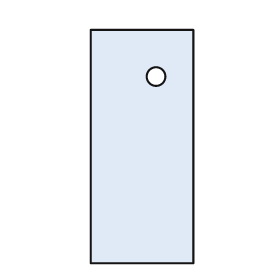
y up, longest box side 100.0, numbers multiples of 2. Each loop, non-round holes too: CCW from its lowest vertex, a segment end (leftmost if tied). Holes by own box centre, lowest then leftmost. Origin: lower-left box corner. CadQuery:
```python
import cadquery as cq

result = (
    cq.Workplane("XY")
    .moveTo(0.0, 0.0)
    .lineTo(44.0, 0.0)
    .lineTo(44.0, 100.0)
    .lineTo(0.0, 100.0)
    .close()
    .moveTo(28.0, 80.0)
    .circle(4.0)
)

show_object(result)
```